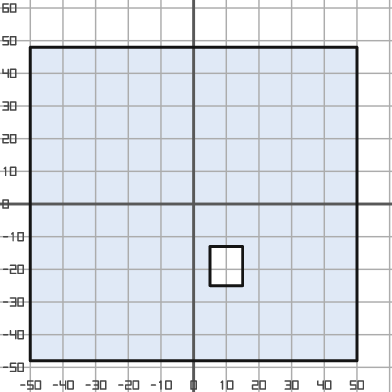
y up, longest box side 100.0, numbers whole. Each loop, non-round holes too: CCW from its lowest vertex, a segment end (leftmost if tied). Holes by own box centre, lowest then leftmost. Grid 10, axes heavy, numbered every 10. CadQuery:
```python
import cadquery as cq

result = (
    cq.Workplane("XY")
    .moveTo(-50.0, -48.0)
    .lineTo(50.0, -48.0)
    .lineTo(50.0, 48.0)
    .lineTo(-50.0, 48.0)
    .close()
    .moveTo(5.0, -25.0)
    .lineTo(15.0, -25.0)
    .lineTo(15.0, -13.0)
    .lineTo(5.0, -13.0)
    .close()
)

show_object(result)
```